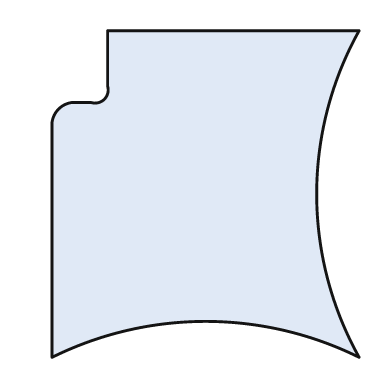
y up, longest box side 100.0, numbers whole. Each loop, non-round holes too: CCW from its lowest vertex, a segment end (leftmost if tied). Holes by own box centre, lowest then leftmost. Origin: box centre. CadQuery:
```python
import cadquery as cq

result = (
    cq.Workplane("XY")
    .moveTo(-47.0, -50.0)
    .threePointArc((0.0, -39.0), (47.0, -50.0))
    .threePointArc((34.0, 0.0), (47.0, 50.0))
    .lineTo(-30.0, 50.0)
    .lineTo(-30.0, 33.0)
    .threePointArc((-31.0, 29.0), (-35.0, 28.0))
    .lineTo(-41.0, 28.0)
    .threePointArc((-45.0, 26.0), (-47.0, 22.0))
    .close()
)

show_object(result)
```